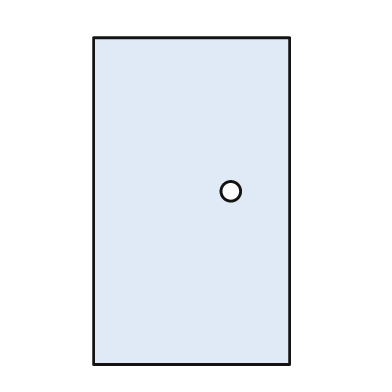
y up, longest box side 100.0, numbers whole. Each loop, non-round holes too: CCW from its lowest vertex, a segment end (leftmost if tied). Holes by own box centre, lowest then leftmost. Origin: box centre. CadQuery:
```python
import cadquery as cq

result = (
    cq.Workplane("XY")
    .moveTo(-30.0, -50.0)
    .lineTo(30.0, -50.0)
    .lineTo(30.0, 50.0)
    .lineTo(-30.0, 50.0)
    .close()
    .moveTo(12.0, 3.0)
    .circle(3.0)
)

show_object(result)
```